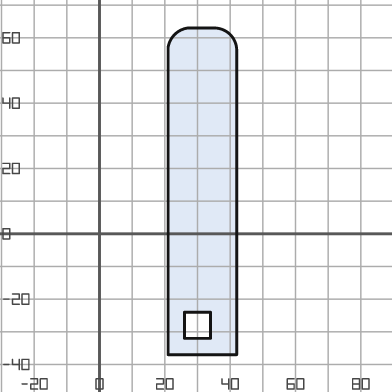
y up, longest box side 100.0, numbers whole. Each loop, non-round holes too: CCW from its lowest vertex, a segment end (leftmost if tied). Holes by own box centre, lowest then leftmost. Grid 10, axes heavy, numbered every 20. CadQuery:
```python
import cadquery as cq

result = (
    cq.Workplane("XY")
    .moveTo(21.0, -37.0)
    .lineTo(42.0, -37.0)
    .lineTo(42.0, 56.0)
    .threePointArc((40.0, 61.0), (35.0, 63.0))
    .lineTo(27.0, 63.0)
    .threePointArc((23.0, 61.0), (21.0, 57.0))
    .close()
    .moveTo(26.0, -32.0)
    .lineTo(34.0, -32.0)
    .lineTo(34.0, -24.0)
    .lineTo(26.0, -24.0)
    .close()
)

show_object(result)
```